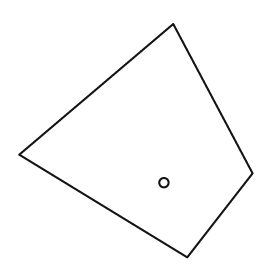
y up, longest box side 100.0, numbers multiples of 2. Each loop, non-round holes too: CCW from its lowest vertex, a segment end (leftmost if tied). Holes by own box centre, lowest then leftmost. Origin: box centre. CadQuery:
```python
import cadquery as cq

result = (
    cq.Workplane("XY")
    .moveTo(22.0, -50.0)
    .lineTo(50.0, -14.0)
    .lineTo(16.0, 50.0)
    .lineTo(-50.0, -6.0)
    .close()
    .moveTo(12.0, -18.0)
    .circle(2.0)
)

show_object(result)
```